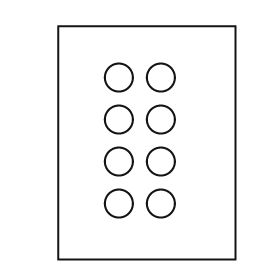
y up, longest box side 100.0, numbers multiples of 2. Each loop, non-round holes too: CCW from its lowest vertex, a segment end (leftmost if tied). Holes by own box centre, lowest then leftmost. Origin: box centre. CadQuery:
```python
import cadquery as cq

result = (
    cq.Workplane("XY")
    .moveTo(-38.0, -50.0)
    .lineTo(38.0, -50.0)
    .lineTo(38.0, 50.0)
    .lineTo(-38.0, 50.0)
    .close()
    .moveTo(-12.0, -26.0)
    .circle(6.0)
    .moveTo(6.0, -26.0)
    .circle(6.0)
    .moveTo(-12.0, -8.0)
    .circle(6.0)
    .moveTo(6.0, -8.0)
    .circle(6.0)
    .moveTo(-12.0, 10.0)
    .circle(6.0)
    .moveTo(6.0, 10.0)
    .circle(6.0)
    .moveTo(-12.0, 28.0)
    .circle(6.0)
    .moveTo(6.0, 28.0)
    .circle(6.0)
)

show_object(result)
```